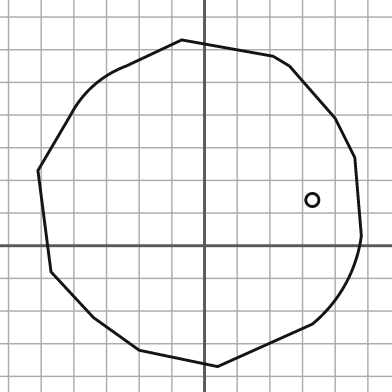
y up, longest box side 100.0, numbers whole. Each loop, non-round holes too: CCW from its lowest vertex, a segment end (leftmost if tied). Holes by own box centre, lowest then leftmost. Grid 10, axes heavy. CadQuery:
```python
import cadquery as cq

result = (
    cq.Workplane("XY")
    .moveTo(4.0, -37.0)
    .lineTo(33.0, -24.0)
    .threePointArc((43.0, -12.0), (48.0, 3.0))
    .lineTo(46.0, 27.0)
    .lineTo(40.0, 39.0)
    .lineTo(26.0, 55.0)
    .lineTo(21.0, 58.0)
    .lineTo(-7.0, 63.0)
    .lineTo(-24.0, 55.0)
    .threePointArc((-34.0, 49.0), (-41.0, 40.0))
    .lineTo(-51.0, 23.0)
    .lineTo(-47.0, -8.0)
    .lineTo(-34.0, -22.0)
    .lineTo(-20.0, -32.0)
    .close()
    .moveTo(33.0, 14.0)
    .circle(2.0)
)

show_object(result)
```